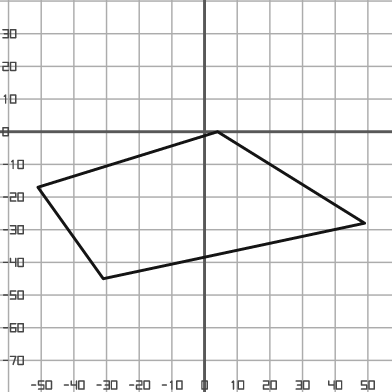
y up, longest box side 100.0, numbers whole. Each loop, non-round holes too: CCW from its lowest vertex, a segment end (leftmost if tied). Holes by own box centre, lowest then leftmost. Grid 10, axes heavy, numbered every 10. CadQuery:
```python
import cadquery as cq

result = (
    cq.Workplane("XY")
    .moveTo(-31.0, -45.0)
    .lineTo(49.0, -28.0)
    .lineTo(4.0, 0.0)
    .lineTo(-51.0, -17.0)
    .close()
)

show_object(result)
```